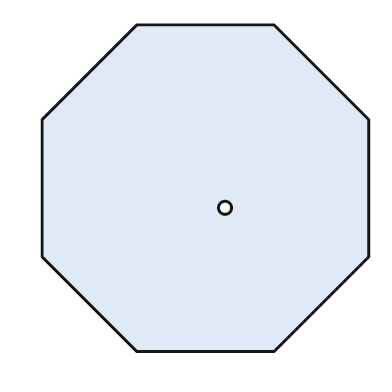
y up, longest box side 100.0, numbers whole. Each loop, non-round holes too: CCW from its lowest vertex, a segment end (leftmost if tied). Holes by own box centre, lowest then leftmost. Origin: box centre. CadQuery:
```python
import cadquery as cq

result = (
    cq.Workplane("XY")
    .moveTo(-21.0, -50.0)
    .lineTo(21.0, -50.0)
    .lineTo(50.0, -21.0)
    .lineTo(50.0, 21.0)
    .lineTo(21.0, 50.0)
    .lineTo(-21.0, 50.0)
    .lineTo(-50.0, 21.0)
    .lineTo(-50.0, -21.0)
    .close()
    .moveTo(6.0, -6.0)
    .circle(2.0)
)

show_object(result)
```